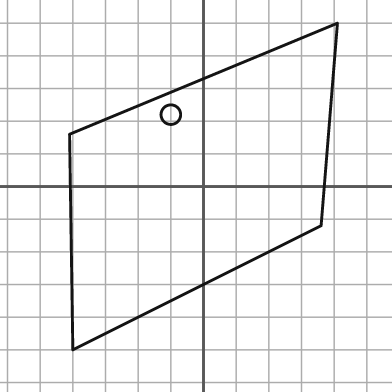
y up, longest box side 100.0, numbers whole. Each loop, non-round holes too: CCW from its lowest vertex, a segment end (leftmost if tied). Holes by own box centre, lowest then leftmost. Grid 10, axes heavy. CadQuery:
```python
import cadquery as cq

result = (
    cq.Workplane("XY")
    .moveTo(-40.0, -50.0)
    .lineTo(36.0, -12.0)
    .lineTo(41.0, 50.0)
    .lineTo(-41.0, 16.0)
    .close()
    .moveTo(-10.0, 22.0)
    .circle(3.0)
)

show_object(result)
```